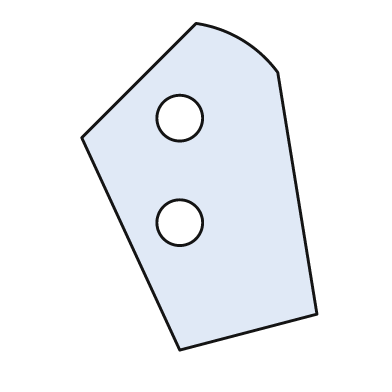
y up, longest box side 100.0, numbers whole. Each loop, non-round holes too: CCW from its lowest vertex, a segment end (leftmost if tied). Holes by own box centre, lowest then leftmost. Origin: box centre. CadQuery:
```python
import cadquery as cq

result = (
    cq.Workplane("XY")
    .moveTo(-6.0, -50.0)
    .lineTo(36.0, -39.0)
    .lineTo(24.0, 35.0)
    .threePointArc((13.0, 45.0), (-1.0, 50.0))
    .lineTo(-36.0, 15.0)
    .close()
    .moveTo(-6.0, -11.0)
    .circle(7.0)
    .moveTo(-6.0, 21.0)
    .circle(7.0)
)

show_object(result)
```